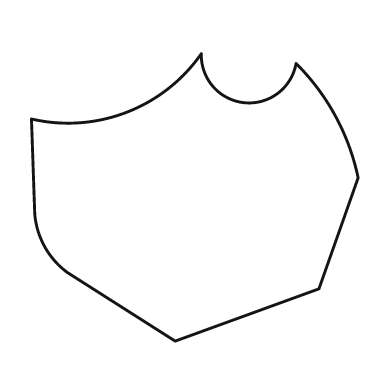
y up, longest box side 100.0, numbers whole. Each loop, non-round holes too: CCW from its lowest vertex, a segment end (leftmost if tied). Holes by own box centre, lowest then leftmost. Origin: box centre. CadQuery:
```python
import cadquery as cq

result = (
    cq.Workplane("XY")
    .moveTo(-6.0, -44.0)
    .lineTo(38.0, -28.0)
    .lineTo(50.0, 6.0)
    .threePointArc((43.0, 25.0), (31.0, 41.0))
    .threePointArc((15.0, 29.0), (2.0, 44.0))
    .threePointArc((-21.0, 26.0), (-50.0, 24.0))
    .lineTo(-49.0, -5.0)
    .threePointArc((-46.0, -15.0), (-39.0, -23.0))
    .close()
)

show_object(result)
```